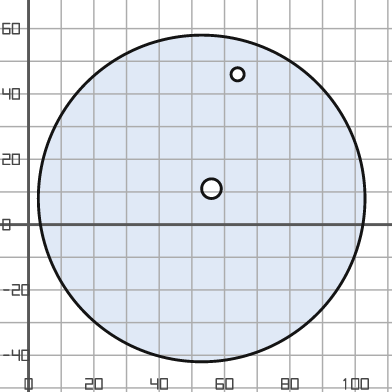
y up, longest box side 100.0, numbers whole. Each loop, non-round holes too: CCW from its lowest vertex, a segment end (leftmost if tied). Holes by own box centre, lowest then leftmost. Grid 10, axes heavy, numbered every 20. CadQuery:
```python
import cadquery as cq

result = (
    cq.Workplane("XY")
    .moveTo(53.0, 8.0)
    .circle(50.0)
    .moveTo(56.0, 11.0)
    .circle(3.0)
    .moveTo(64.0, 46.0)
    .circle(2.0)
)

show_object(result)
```